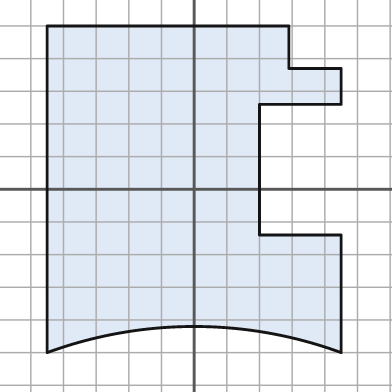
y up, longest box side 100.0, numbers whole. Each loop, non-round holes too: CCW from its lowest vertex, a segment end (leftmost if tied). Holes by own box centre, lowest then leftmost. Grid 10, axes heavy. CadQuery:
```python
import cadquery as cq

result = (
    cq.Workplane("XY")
    .moveTo(-45.0, -50.0)
    .threePointArc((0.0, -42.0), (45.0, -50.0))
    .lineTo(45.0, -14.0)
    .lineTo(20.0, -14.0)
    .lineTo(20.0, 26.0)
    .lineTo(45.0, 26.0)
    .lineTo(45.0, 37.0)
    .lineTo(29.0, 37.0)
    .lineTo(29.0, 50.0)
    .lineTo(-45.0, 50.0)
    .close()
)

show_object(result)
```